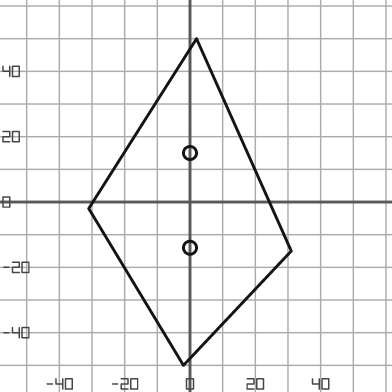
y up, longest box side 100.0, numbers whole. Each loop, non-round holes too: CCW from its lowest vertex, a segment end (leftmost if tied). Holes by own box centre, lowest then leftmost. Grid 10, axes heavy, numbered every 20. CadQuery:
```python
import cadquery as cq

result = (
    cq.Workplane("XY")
    .moveTo(-2.0, -50.0)
    .lineTo(31.0, -15.0)
    .lineTo(2.0, 50.0)
    .lineTo(-31.0, -2.0)
    .close()
    .moveTo(0.0, -14.0)
    .circle(2.0)
    .moveTo(0.0, 15.0)
    .circle(2.0)
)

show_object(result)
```